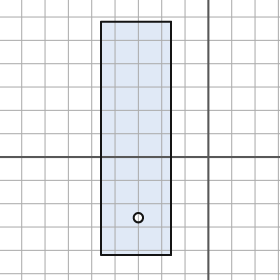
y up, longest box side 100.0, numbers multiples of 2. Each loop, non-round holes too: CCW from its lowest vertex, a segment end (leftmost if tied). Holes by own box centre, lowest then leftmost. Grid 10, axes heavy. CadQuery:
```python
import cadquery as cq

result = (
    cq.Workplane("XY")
    .moveTo(-46.0, -42.0)
    .lineTo(-16.0, -42.0)
    .lineTo(-16.0, 58.0)
    .lineTo(-46.0, 58.0)
    .close()
    .moveTo(-30.0, -26.0)
    .circle(2.0)
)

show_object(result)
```